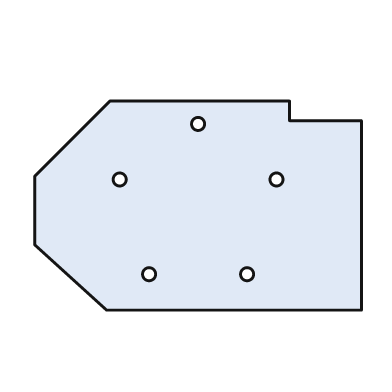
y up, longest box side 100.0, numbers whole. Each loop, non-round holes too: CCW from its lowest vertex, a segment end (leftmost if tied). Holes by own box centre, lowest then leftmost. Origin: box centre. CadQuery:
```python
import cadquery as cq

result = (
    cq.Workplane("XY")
    .moveTo(-28.0, -32.0)
    .lineTo(50.0, -32.0)
    .lineTo(50.0, 26.0)
    .lineTo(28.0, 26.0)
    .lineTo(28.0, 32.0)
    .lineTo(-27.0, 32.0)
    .lineTo(-50.0, 9.0)
    .lineTo(-50.0, -12.0)
    .close()
    .moveTo(-15.0, -21.0)
    .circle(2.0)
    .moveTo(15.0, -21.0)
    .circle(2.0)
    .moveTo(-24.0, 8.0)
    .circle(2.0)
    .moveTo(24.0, 8.0)
    .circle(2.0)
    .moveTo(0.0, 25.0)
    .circle(2.0)
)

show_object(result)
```